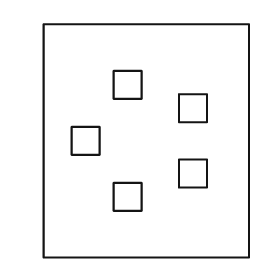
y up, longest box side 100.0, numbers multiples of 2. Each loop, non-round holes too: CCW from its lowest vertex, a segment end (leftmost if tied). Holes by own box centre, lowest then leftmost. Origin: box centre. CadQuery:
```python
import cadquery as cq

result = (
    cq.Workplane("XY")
    .moveTo(-44.0, -50.0)
    .lineTo(44.0, -50.0)
    .lineTo(44.0, 50.0)
    .lineTo(-44.0, 50.0)
    .close()
    .moveTo(-14.0, -30.0)
    .lineTo(-2.0, -30.0)
    .lineTo(-2.0, -18.0)
    .lineTo(-14.0, -18.0)
    .close()
    .moveTo(14.0, -20.0)
    .lineTo(26.0, -20.0)
    .lineTo(26.0, -8.0)
    .lineTo(14.0, -8.0)
    .close()
    .moveTo(-32.0, -6.0)
    .lineTo(-20.0, -6.0)
    .lineTo(-20.0, 6.0)
    .lineTo(-32.0, 6.0)
    .close()
    .moveTo(14.0, 8.0)
    .lineTo(26.0, 8.0)
    .lineTo(26.0, 20.0)
    .lineTo(14.0, 20.0)
    .close()
    .moveTo(-14.0, 18.0)
    .lineTo(-2.0, 18.0)
    .lineTo(-2.0, 30.0)
    .lineTo(-14.0, 30.0)
    .close()
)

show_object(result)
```